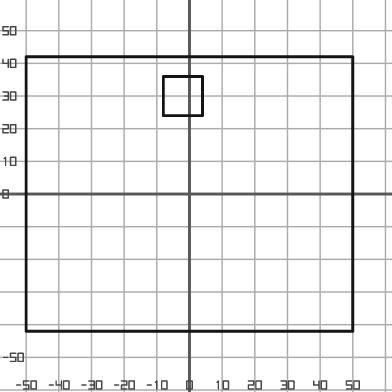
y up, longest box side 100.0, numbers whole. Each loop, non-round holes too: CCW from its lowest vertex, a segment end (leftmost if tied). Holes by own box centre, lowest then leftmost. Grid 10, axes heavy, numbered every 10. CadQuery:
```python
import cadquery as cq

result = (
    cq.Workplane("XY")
    .moveTo(-50.0, -42.0)
    .lineTo(50.0, -42.0)
    .lineTo(50.0, 42.0)
    .lineTo(-50.0, 42.0)
    .close()
    .moveTo(-8.0, 24.0)
    .lineTo(4.0, 24.0)
    .lineTo(4.0, 36.0)
    .lineTo(-8.0, 36.0)
    .close()
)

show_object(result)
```